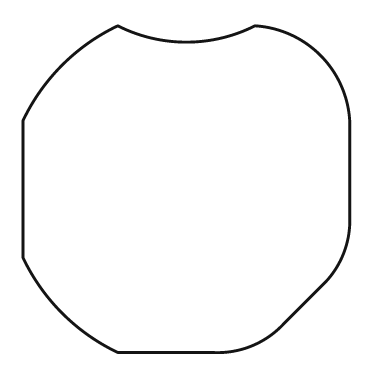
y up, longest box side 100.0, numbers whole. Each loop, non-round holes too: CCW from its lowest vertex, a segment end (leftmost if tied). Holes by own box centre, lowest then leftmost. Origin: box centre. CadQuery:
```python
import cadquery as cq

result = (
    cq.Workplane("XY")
    .moveTo(-21.0, -50.0)
    .lineTo(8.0, -50.0)
    .threePointArc((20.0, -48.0), (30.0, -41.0))
    .lineTo(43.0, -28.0)
    .threePointArc((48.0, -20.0), (50.0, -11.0))
    .lineTo(50.0, 21.0)
    .threePointArc((41.0, 41.0), (21.0, 50.0))
    .threePointArc((0.0, 45.0), (-21.0, 50.0))
    .threePointArc((-38.0, 38.0), (-50.0, 21.0))
    .lineTo(-50.0, -21.0)
    .threePointArc((-38.0, -38.0), (-21.0, -50.0))
    .close()
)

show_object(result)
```